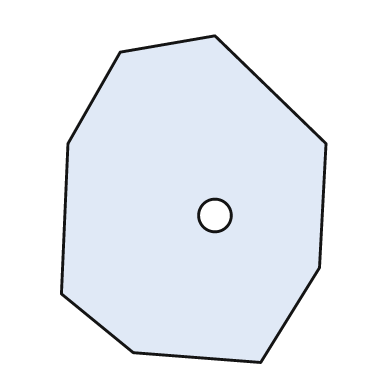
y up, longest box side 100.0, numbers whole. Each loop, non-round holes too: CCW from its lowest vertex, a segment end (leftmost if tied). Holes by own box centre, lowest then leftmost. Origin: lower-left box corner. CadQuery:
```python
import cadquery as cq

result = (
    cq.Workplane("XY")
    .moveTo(61.0, 0.0)
    .lineTo(79.0, 29.0)
    .lineTo(81.0, 67.0)
    .lineTo(47.0, 100.0)
    .lineTo(18.0, 95.0)
    .lineTo(2.0, 67.0)
    .lineTo(0.0, 21.0)
    .lineTo(22.0, 3.0)
    .close()
    .moveTo(47.0, 45.0)
    .circle(5.0)
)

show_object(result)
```